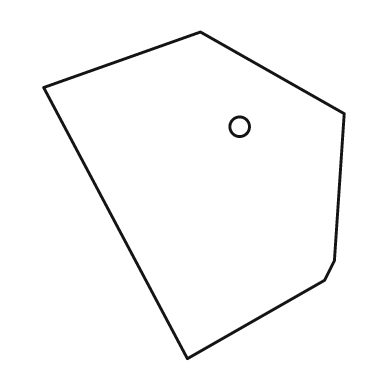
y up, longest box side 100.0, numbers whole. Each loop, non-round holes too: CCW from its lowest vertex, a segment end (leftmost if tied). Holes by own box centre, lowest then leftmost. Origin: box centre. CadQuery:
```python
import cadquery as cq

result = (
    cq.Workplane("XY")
    .moveTo(-2.0, -50.0)
    .lineTo(40.0, -26.0)
    .lineTo(43.0, -20.0)
    .lineTo(46.0, 25.0)
    .lineTo(2.0, 50.0)
    .lineTo(-46.0, 33.0)
    .close()
    .moveTo(14.0, 21.0)
    .circle(3.0)
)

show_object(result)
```